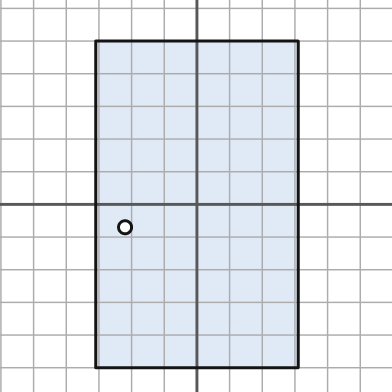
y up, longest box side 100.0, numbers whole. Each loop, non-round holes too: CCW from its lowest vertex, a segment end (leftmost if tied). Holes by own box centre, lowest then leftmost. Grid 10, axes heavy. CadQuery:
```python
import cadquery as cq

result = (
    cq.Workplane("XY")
    .moveTo(-31.0, -50.0)
    .lineTo(31.0, -50.0)
    .lineTo(31.0, 50.0)
    .lineTo(-31.0, 50.0)
    .close()
    .moveTo(-22.0, -7.0)
    .circle(2.0)
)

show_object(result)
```